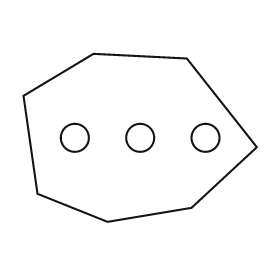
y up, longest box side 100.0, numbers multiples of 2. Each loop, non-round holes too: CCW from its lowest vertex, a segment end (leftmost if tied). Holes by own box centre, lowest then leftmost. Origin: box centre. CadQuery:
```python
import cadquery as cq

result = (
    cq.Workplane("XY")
    .moveTo(-14.0, -36.0)
    .lineTo(22.0, -30.0)
    .lineTo(50.0, -4.0)
    .lineTo(20.0, 34.0)
    .lineTo(-20.0, 36.0)
    .lineTo(-50.0, 18.0)
    .lineTo(-44.0, -24.0)
    .close()
    .moveTo(-28.0, 0.0)
    .circle(6.0)
    .moveTo(0.0, 0.0)
    .circle(6.0)
    .moveTo(28.0, 0.0)
    .circle(6.0)
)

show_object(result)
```